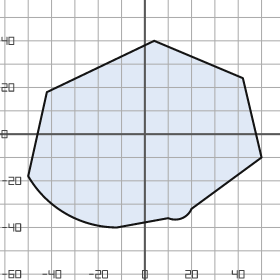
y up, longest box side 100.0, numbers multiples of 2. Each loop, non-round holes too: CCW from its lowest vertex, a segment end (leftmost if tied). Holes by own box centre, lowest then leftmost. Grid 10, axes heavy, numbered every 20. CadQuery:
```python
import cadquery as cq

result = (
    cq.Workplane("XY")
    .moveTo(-12.0, -40.0)
    .lineTo(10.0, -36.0)
    .threePointArc((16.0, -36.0), (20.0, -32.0))
    .lineTo(50.0, -10.0)
    .lineTo(42.0, 24.0)
    .lineTo(4.0, 40.0)
    .lineTo(-42.0, 18.0)
    .lineTo(-50.0, -18.0)
    .threePointArc((-34.0, -34.0), (-12.0, -40.0))
    .close()
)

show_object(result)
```